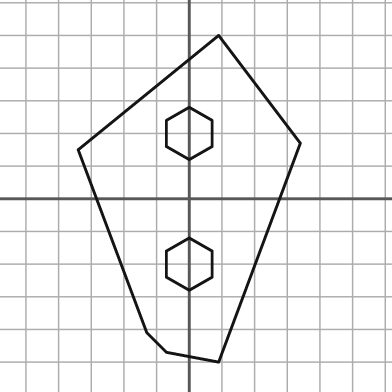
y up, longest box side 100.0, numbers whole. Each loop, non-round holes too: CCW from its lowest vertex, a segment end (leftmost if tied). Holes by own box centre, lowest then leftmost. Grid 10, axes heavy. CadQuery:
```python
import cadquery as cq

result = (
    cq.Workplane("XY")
    .moveTo(9.0, -50.0)
    .lineTo(34.0, 17.0)
    .lineTo(9.0, 50.0)
    .lineTo(-34.0, 15.0)
    .lineTo(-13.0, -41.0)
    .lineTo(-7.0, -47.0)
    .close()
    .moveTo(0.0, -28.0)
    .lineTo(7.0, -24.0)
    .lineTo(7.0, -16.0)
    .lineTo(0.0, -12.0)
    .lineTo(-7.0, -16.0)
    .lineTo(-7.0, -24.0)
    .close()
    .moveTo(0.0, 12.0)
    .lineTo(7.0, 16.0)
    .lineTo(7.0, 24.0)
    .lineTo(0.0, 28.0)
    .lineTo(-7.0, 24.0)
    .lineTo(-7.0, 16.0)
    .close()
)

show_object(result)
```